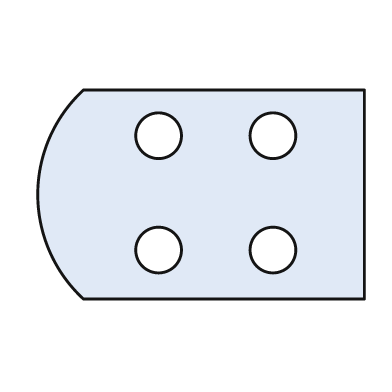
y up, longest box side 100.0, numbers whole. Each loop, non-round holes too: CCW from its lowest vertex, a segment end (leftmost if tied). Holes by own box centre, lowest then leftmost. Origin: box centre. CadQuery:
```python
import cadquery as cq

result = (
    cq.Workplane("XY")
    .moveTo(-36.0, -32.0)
    .lineTo(50.0, -32.0)
    .lineTo(50.0, 32.0)
    .lineTo(-36.0, 32.0)
    .threePointArc((-50.0, 0.0), (-36.0, -32.0))
    .close()
    .moveTo(-13.0, -17.0)
    .circle(7.0)
    .moveTo(22.0, -17.0)
    .circle(7.0)
    .moveTo(-13.0, 18.0)
    .circle(7.0)
    .moveTo(22.0, 18.0)
    .circle(7.0)
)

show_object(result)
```